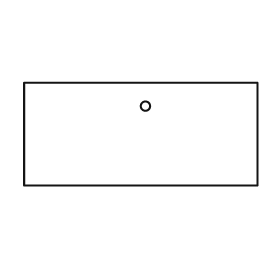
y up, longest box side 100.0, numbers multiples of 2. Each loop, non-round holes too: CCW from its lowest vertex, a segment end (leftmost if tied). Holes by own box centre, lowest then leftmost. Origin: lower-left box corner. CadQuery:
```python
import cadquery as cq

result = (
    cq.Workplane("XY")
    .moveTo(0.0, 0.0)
    .lineTo(100.0, 0.0)
    .lineTo(100.0, 44.0)
    .lineTo(0.0, 44.0)
    .close()
    .moveTo(52.0, 34.0)
    .circle(2.0)
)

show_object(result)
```